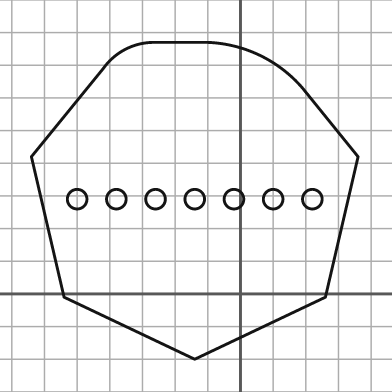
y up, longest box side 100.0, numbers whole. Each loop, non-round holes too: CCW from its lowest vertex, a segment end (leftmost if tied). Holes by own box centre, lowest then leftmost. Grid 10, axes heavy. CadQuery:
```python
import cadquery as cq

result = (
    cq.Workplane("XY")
    .moveTo(-14.0, -20.0)
    .lineTo(26.0, -1.0)
    .lineTo(36.0, 42.0)
    .lineTo(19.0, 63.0)
    .threePointArc((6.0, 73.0), (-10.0, 77.0))
    .lineTo(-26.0, 77.0)
    .threePointArc((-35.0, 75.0), (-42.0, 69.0))
    .lineTo(-64.0, 42.0)
    .lineTo(-54.0, -1.0)
    .close()
    .moveTo(-50.0, 29.0)
    .circle(3.0)
    .moveTo(-38.0, 29.0)
    .circle(3.0)
    .moveTo(-26.0, 29.0)
    .circle(3.0)
    .moveTo(-14.0, 29.0)
    .circle(3.0)
    .moveTo(-2.0, 29.0)
    .circle(3.0)
    .moveTo(10.0, 29.0)
    .circle(3.0)
    .moveTo(22.0, 29.0)
    .circle(3.0)
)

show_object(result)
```